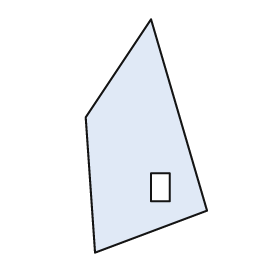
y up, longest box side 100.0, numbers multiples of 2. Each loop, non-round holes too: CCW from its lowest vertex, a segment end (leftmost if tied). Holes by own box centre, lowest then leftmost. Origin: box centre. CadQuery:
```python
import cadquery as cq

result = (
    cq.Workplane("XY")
    .moveTo(-22.0, -50.0)
    .lineTo(26.0, -32.0)
    .lineTo(2.0, 50.0)
    .lineTo(-26.0, 8.0)
    .close()
    .moveTo(2.0, -28.0)
    .lineTo(10.0, -28.0)
    .lineTo(10.0, -16.0)
    .lineTo(2.0, -16.0)
    .close()
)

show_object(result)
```